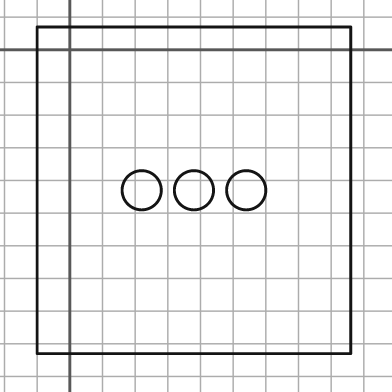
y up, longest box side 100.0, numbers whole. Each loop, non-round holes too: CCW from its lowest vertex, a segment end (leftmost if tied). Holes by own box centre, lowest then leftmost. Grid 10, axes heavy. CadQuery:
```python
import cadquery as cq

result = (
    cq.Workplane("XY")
    .moveTo(-10.0, -93.0)
    .lineTo(86.0, -93.0)
    .lineTo(86.0, 7.0)
    .lineTo(-10.0, 7.0)
    .close()
    .moveTo(22.0, -43.0)
    .circle(6.0)
    .moveTo(38.0, -43.0)
    .circle(6.0)
    .moveTo(54.0, -43.0)
    .circle(6.0)
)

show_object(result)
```